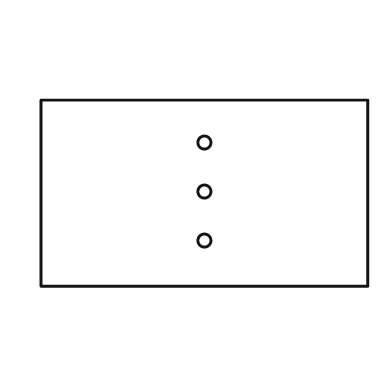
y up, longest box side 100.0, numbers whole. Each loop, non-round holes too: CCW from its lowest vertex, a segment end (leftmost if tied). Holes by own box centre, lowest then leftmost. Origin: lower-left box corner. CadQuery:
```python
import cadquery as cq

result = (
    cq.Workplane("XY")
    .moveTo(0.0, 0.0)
    .lineTo(100.0, 0.0)
    .lineTo(100.0, 57.0)
    .lineTo(0.0, 57.0)
    .close()
    .moveTo(50.0, 14.0)
    .circle(2.0)
    .moveTo(50.0, 29.0)
    .circle(2.0)
    .moveTo(50.0, 44.0)
    .circle(2.0)
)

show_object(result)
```